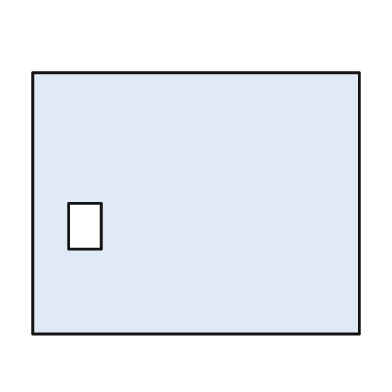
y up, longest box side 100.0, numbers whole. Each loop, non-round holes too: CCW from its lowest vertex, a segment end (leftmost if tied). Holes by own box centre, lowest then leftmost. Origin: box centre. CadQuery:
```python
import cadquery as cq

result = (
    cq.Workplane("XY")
    .moveTo(-50.0, -40.0)
    .lineTo(50.0, -40.0)
    .lineTo(50.0, 40.0)
    .lineTo(-50.0, 40.0)
    .close()
    .moveTo(-39.0, -14.0)
    .lineTo(-29.0, -14.0)
    .lineTo(-29.0, 0.0)
    .lineTo(-39.0, 0.0)
    .close()
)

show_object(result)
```